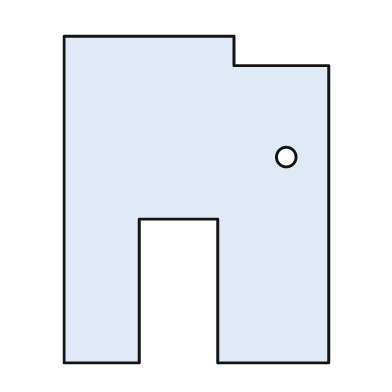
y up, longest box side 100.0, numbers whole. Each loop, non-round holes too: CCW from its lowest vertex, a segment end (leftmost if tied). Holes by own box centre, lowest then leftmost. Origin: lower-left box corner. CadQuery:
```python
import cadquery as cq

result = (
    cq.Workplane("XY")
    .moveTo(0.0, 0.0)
    .lineTo(23.0, 0.0)
    .lineTo(23.0, 44.0)
    .lineTo(47.0, 44.0)
    .lineTo(47.0, 0.0)
    .lineTo(81.0, 0.0)
    .lineTo(81.0, 91.0)
    .lineTo(52.0, 91.0)
    .lineTo(52.0, 100.0)
    .lineTo(0.0, 100.0)
    .close()
    .moveTo(68.0, 63.0)
    .circle(3.0)
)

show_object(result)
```